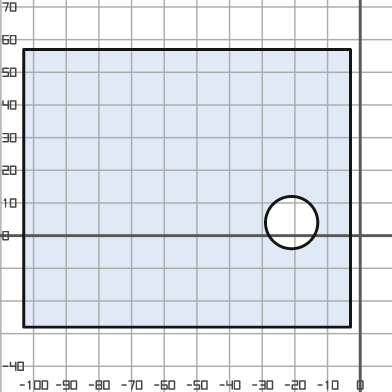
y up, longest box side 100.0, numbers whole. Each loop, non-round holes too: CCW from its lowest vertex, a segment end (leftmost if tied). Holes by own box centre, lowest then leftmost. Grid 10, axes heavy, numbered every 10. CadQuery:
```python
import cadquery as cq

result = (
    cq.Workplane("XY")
    .moveTo(-103.0, -28.0)
    .lineTo(-3.0, -28.0)
    .lineTo(-3.0, 57.0)
    .lineTo(-103.0, 57.0)
    .close()
    .moveTo(-21.0, 4.0)
    .circle(8.0)
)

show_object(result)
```